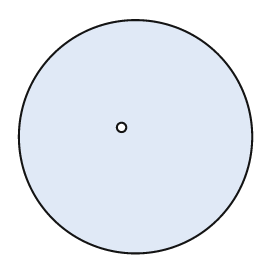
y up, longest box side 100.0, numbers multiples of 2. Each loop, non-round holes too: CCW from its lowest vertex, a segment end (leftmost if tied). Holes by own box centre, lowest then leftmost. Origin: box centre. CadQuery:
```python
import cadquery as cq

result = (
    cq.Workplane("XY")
    .moveTo(0.0, 0.0)
    .circle(50.0)
    .moveTo(-6.0, 4.0)
    .circle(2.0)
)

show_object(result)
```